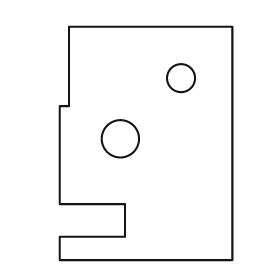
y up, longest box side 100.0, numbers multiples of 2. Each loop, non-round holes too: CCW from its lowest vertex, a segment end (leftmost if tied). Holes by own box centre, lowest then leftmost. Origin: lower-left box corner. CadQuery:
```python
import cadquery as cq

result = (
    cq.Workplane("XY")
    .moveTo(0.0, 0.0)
    .lineTo(74.0, 0.0)
    .lineTo(74.0, 100.0)
    .lineTo(4.0, 100.0)
    .lineTo(4.0, 66.0)
    .lineTo(0.0, 66.0)
    .lineTo(0.0, 24.0)
    .lineTo(28.0, 24.0)
    .lineTo(28.0, 10.0)
    .lineTo(0.0, 10.0)
    .close()
    .moveTo(26.0, 52.0)
    .circle(8.0)
    .moveTo(52.0, 78.0)
    .circle(6.0)
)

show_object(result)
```